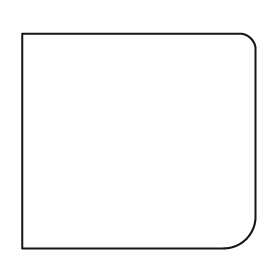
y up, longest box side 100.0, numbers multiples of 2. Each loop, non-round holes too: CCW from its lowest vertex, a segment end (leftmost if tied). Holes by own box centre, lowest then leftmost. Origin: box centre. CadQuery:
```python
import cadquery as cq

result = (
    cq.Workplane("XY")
    .moveTo(-50.0, -46.0)
    .lineTo(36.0, -46.0)
    .threePointArc((46.0, -42.0), (50.0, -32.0))
    .lineTo(50.0, 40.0)
    .threePointArc((48.0, 44.0), (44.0, 46.0))
    .lineTo(-50.0, 46.0)
    .close()
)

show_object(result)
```